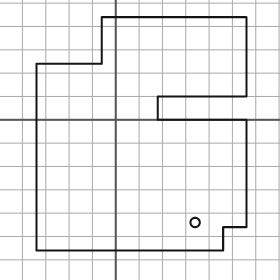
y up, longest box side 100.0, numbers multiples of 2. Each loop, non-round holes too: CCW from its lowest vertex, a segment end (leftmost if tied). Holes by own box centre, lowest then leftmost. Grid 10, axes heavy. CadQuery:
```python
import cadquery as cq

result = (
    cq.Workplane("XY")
    .moveTo(-34.0, -56.0)
    .lineTo(46.0, -56.0)
    .lineTo(46.0, -46.0)
    .lineTo(56.0, -46.0)
    .lineTo(56.0, 0.0)
    .lineTo(18.0, 0.0)
    .lineTo(18.0, 10.0)
    .lineTo(56.0, 10.0)
    .lineTo(56.0, 44.0)
    .lineTo(-6.0, 44.0)
    .lineTo(-6.0, 24.0)
    .lineTo(-34.0, 24.0)
    .close()
    .moveTo(34.0, -44.0)
    .circle(2.0)
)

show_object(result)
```